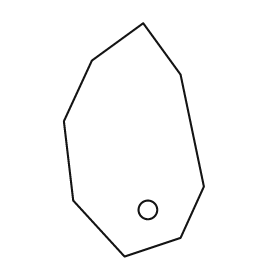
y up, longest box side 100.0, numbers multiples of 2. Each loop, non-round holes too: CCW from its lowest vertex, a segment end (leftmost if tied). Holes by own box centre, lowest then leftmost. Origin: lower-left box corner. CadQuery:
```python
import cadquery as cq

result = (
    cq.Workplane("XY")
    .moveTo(26.0, 0.0)
    .lineTo(50.0, 8.0)
    .lineTo(60.0, 30.0)
    .lineTo(50.0, 78.0)
    .lineTo(34.0, 100.0)
    .lineTo(12.0, 84.0)
    .lineTo(0.0, 58.0)
    .lineTo(4.0, 24.0)
    .close()
    .moveTo(36.0, 20.0)
    .circle(4.0)
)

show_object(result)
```